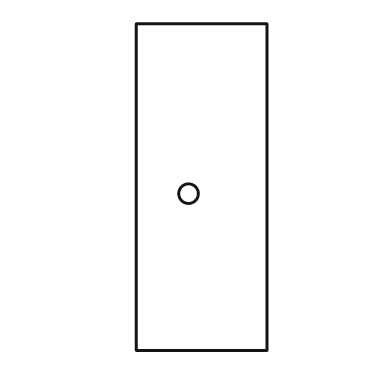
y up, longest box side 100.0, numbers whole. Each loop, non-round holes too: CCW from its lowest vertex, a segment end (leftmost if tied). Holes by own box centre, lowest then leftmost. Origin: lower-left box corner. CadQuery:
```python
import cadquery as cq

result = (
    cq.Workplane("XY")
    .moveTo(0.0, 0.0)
    .lineTo(40.0, 0.0)
    .lineTo(40.0, 100.0)
    .lineTo(0.0, 100.0)
    .close()
    .moveTo(16.0, 48.0)
    .circle(3.0)
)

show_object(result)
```